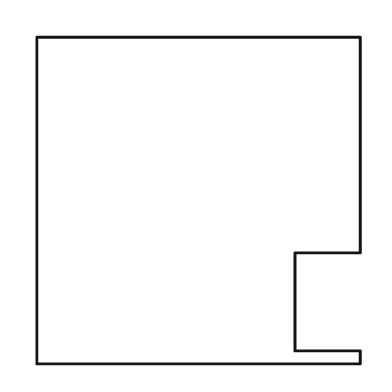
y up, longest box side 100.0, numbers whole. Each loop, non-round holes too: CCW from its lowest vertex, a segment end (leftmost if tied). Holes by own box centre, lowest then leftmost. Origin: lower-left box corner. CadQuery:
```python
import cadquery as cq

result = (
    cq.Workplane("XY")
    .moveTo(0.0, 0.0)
    .lineTo(99.0, 0.0)
    .lineTo(99.0, 4.0)
    .lineTo(79.0, 4.0)
    .lineTo(79.0, 34.0)
    .lineTo(99.0, 34.0)
    .lineTo(99.0, 100.0)
    .lineTo(0.0, 100.0)
    .close()
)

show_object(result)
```